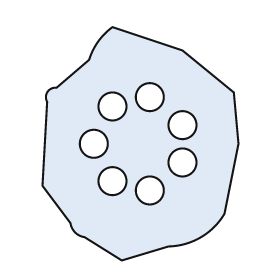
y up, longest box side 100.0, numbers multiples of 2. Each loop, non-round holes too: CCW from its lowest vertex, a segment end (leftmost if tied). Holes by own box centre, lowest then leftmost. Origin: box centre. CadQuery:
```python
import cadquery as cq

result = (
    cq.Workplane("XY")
    .moveTo(-8.0, -50.0)
    .lineTo(12.0, -44.0)
    .threePointArc((26.0, -40.0), (36.0, -30.0))
    .lineTo(42.0, 0.0)
    .lineTo(40.0, 22.0)
    .lineTo(18.0, 40.0)
    .lineTo(-12.0, 50.0)
    .threePointArc((-18.0, 44.0), (-22.0, 36.0))
    .lineTo(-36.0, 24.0)
    .threePointArc((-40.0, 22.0), (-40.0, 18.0))
    .lineTo(-42.0, -18.0)
    .lineTo(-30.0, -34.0)
    .threePointArc((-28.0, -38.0), (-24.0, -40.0))
    .close()
    .moveTo(4.0, -20.0)
    .circle(6.0)
    .moveTo(-12.0, -16.0)
    .circle(6.0)
    .moveTo(18.0, -8.0)
    .circle(6.0)
    .moveTo(-20.0, 0.0)
    .circle(6.0)
    .moveTo(18.0, 8.0)
    .circle(6.0)
    .moveTo(-12.0, 16.0)
    .circle(6.0)
    .moveTo(4.0, 20.0)
    .circle(6.0)
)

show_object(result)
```